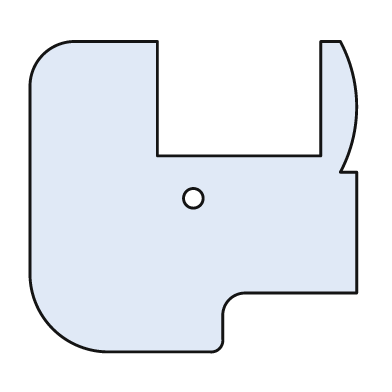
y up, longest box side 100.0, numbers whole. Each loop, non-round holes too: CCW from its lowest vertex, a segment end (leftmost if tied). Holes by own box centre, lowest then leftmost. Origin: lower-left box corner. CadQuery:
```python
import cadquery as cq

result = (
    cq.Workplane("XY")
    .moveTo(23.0, 0.0)
    .lineTo(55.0, 0.0)
    .threePointArc((58.0, 1.0), (59.0, 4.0))
    .lineTo(59.0, 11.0)
    .threePointArc((61.0, 16.0), (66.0, 18.0))
    .lineTo(100.0, 18.0)
    .lineTo(100.0, 55.0)
    .lineTo(95.0, 55.0)
    .threePointArc((100.0, 75.0), (95.0, 95.0))
    .lineTo(89.0, 95.0)
    .lineTo(89.0, 60.0)
    .lineTo(39.0, 60.0)
    .lineTo(39.0, 95.0)
    .lineTo(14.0, 95.0)
    .threePointArc((4.0, 91.0), (0.0, 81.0))
    .lineTo(0.0, 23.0)
    .threePointArc((7.0, 7.0), (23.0, 0.0))
    .close()
    .moveTo(50.0, 47.0)
    .circle(3.0)
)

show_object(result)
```